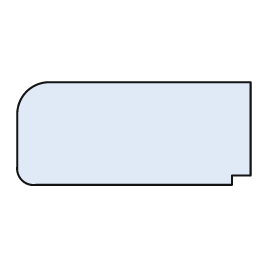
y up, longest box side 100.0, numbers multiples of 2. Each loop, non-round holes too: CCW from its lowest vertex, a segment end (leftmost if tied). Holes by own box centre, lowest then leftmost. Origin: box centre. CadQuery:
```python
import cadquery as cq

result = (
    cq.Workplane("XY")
    .moveTo(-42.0, -22.0)
    .lineTo(42.0, -22.0)
    .lineTo(42.0, -18.0)
    .lineTo(50.0, -18.0)
    .lineTo(50.0, 22.0)
    .lineTo(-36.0, 22.0)
    .threePointArc((-46.0, 18.0), (-50.0, 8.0))
    .lineTo(-50.0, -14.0)
    .threePointArc((-48.0, -20.0), (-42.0, -22.0))
    .close()
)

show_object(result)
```